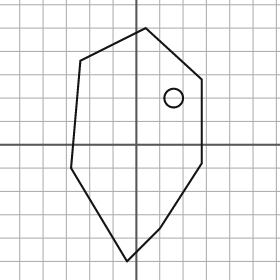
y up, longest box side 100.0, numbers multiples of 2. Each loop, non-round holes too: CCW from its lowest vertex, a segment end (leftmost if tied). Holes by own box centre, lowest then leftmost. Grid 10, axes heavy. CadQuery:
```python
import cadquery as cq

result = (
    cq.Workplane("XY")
    .moveTo(-4.0, -50.0)
    .lineTo(10.0, -36.0)
    .lineTo(28.0, -8.0)
    .lineTo(28.0, 28.0)
    .lineTo(4.0, 50.0)
    .lineTo(-24.0, 36.0)
    .lineTo(-28.0, -10.0)
    .close()
    .moveTo(16.0, 20.0)
    .circle(4.0)
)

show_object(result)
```